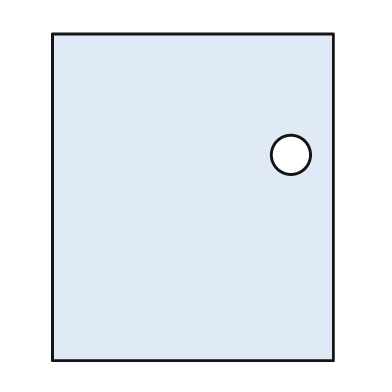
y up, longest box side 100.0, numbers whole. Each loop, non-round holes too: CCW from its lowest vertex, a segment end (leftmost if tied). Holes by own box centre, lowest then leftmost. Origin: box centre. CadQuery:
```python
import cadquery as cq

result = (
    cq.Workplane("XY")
    .moveTo(-43.0, -50.0)
    .lineTo(43.0, -50.0)
    .lineTo(43.0, 50.0)
    .lineTo(-43.0, 50.0)
    .close()
    .moveTo(30.0, 13.0)
    .circle(6.0)
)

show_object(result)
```